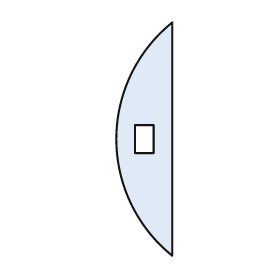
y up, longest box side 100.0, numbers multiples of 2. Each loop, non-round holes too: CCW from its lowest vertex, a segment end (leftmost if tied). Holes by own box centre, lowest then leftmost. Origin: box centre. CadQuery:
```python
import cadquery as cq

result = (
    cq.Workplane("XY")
    .moveTo(12.0, -50.0)
    .lineTo(12.0, 50.0)
    .threePointArc((-12.0, 0.0), (12.0, -50.0))
    .close()
    .moveTo(-4.0, -6.0)
    .lineTo(4.0, -6.0)
    .lineTo(4.0, 6.0)
    .lineTo(-4.0, 6.0)
    .close()
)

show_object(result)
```